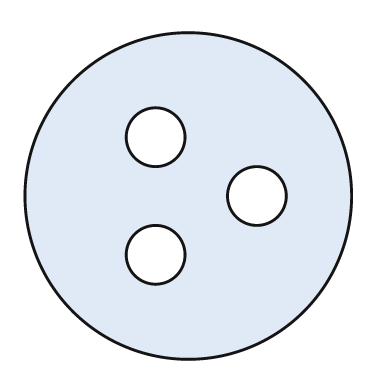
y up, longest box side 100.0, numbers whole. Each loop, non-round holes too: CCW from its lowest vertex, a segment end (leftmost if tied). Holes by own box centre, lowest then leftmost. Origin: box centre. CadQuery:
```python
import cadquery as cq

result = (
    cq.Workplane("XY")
    .moveTo(0.0, 0.0)
    .circle(50.0)
    .moveTo(-10.0, -18.0)
    .circle(9.0)
    .moveTo(21.0, 0.0)
    .circle(9.0)
    .moveTo(-10.0, 18.0)
    .circle(9.0)
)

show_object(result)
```